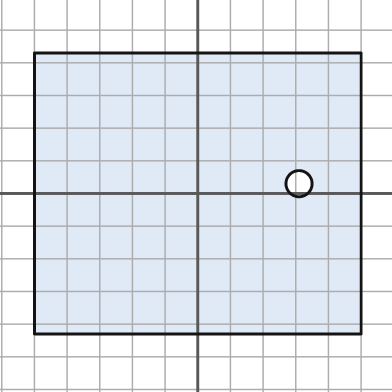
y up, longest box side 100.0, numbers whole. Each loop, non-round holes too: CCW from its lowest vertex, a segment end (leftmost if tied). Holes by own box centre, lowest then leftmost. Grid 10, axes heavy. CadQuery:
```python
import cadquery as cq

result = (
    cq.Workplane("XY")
    .moveTo(-50.0, -43.0)
    .lineTo(50.0, -43.0)
    .lineTo(50.0, 43.0)
    .lineTo(-50.0, 43.0)
    .close()
    .moveTo(31.0, 3.0)
    .circle(4.0)
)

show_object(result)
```